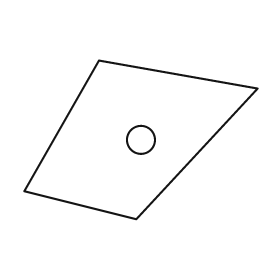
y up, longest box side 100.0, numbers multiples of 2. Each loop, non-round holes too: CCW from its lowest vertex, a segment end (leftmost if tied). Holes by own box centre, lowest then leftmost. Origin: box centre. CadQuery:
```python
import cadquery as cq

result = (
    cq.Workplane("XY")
    .moveTo(-2.0, -34.0)
    .lineTo(50.0, 22.0)
    .lineTo(-18.0, 34.0)
    .lineTo(-50.0, -22.0)
    .close()
    .moveTo(0.0, 0.0)
    .circle(6.0)
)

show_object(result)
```